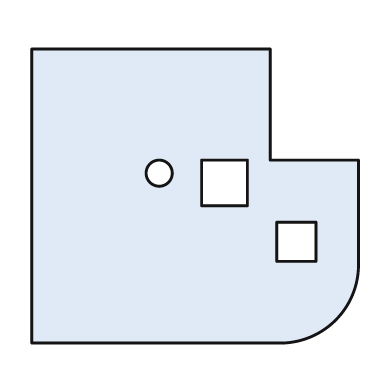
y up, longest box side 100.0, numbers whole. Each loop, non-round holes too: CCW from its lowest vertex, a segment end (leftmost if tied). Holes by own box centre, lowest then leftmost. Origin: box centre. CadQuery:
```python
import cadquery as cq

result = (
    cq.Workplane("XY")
    .moveTo(-50.0, -45.0)
    .lineTo(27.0, -45.0)
    .threePointArc((43.0, -38.0), (50.0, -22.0))
    .lineTo(50.0, 11.0)
    .lineTo(23.0, 11.0)
    .lineTo(23.0, 45.0)
    .lineTo(-50.0, 45.0)
    .close()
    .moveTo(25.0, -20.0)
    .lineTo(37.0, -20.0)
    .lineTo(37.0, -8.0)
    .lineTo(25.0, -8.0)
    .close()
    .moveTo(2.0, -3.0)
    .lineTo(16.0, -3.0)
    .lineTo(16.0, 11.0)
    .lineTo(2.0, 11.0)
    .close()
    .moveTo(-11.0, 7.0)
    .circle(4.0)
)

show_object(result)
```